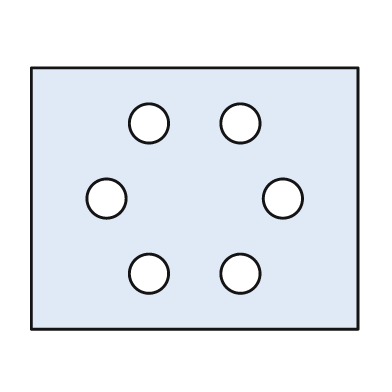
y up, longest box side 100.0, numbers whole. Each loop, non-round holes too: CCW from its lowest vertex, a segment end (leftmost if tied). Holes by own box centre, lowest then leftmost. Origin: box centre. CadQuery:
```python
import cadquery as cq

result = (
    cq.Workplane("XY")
    .moveTo(-50.0, -40.0)
    .lineTo(50.0, -40.0)
    .lineTo(50.0, 40.0)
    .lineTo(-50.0, 40.0)
    .close()
    .moveTo(-14.0, -23.0)
    .circle(6.0)
    .moveTo(14.0, -23.0)
    .circle(6.0)
    .moveTo(-27.0, 0.0)
    .circle(6.0)
    .moveTo(27.0, 0.0)
    .circle(6.0)
    .moveTo(-14.0, 23.0)
    .circle(6.0)
    .moveTo(14.0, 23.0)
    .circle(6.0)
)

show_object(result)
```